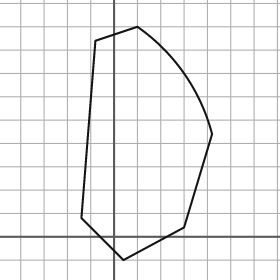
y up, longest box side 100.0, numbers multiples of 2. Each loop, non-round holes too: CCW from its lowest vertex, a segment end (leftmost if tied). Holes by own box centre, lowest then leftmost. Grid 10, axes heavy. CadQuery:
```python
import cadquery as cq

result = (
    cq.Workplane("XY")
    .moveTo(4.0, -10.0)
    .lineTo(30.0, 4.0)
    .lineTo(42.0, 44.0)
    .threePointArc((30.0, 70.0), (10.0, 90.0))
    .lineTo(-8.0, 84.0)
    .lineTo(-14.0, 8.0)
    .close()
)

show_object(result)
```